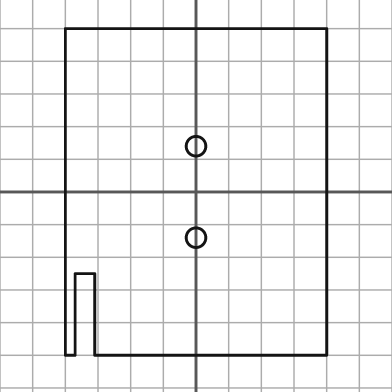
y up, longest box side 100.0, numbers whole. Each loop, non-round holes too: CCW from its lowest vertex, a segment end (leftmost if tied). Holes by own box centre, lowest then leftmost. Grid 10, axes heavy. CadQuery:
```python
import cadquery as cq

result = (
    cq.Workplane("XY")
    .moveTo(-40.0, -50.0)
    .lineTo(-37.0, -50.0)
    .lineTo(-37.0, -25.0)
    .lineTo(-31.0, -25.0)
    .lineTo(-31.0, -50.0)
    .lineTo(40.0, -50.0)
    .lineTo(40.0, 50.0)
    .lineTo(-40.0, 50.0)
    .close()
    .moveTo(0.0, -14.0)
    .circle(3.0)
    .moveTo(0.0, 14.0)
    .circle(3.0)
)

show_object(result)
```